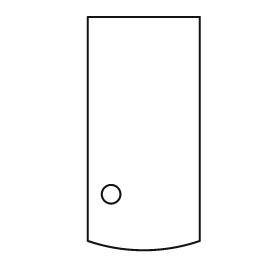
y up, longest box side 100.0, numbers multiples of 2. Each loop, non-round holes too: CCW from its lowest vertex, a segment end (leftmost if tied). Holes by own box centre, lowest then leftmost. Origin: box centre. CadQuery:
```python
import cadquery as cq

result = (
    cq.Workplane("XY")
    .moveTo(-24.0, -46.0)
    .threePointArc((0.0, -50.0), (24.0, -46.0))
    .lineTo(24.0, 50.0)
    .lineTo(-24.0, 50.0)
    .close()
    .moveTo(-14.0, -26.0)
    .circle(4.0)
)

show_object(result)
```